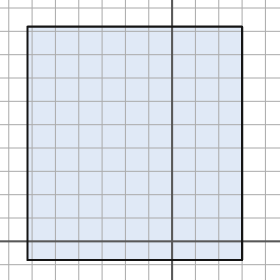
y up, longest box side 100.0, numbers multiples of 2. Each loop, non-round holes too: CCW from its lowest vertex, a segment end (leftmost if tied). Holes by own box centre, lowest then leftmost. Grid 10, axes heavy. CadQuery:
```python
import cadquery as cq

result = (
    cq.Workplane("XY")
    .moveTo(-62.0, -8.0)
    .lineTo(30.0, -8.0)
    .lineTo(30.0, 92.0)
    .lineTo(-62.0, 92.0)
    .close()
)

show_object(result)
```